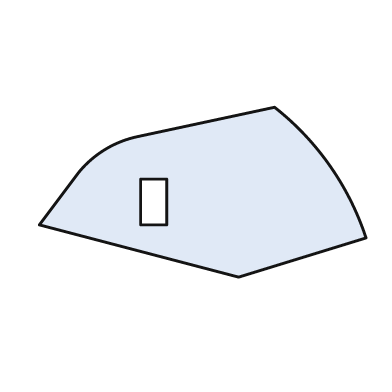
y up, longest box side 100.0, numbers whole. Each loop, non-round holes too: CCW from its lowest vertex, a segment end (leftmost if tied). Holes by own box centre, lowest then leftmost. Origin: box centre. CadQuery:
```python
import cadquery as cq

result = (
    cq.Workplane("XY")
    .moveTo(11.0, -26.0)
    .lineTo(50.0, -14.0)
    .threePointArc((39.0, 8.0), (22.0, 26.0))
    .lineTo(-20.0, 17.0)
    .threePointArc((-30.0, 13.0), (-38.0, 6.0))
    .lineTo(-50.0, -10.0)
    .close()
    .moveTo(-19.0, -10.0)
    .lineTo(-11.0, -10.0)
    .lineTo(-11.0, 4.0)
    .lineTo(-19.0, 4.0)
    .close()
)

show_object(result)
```